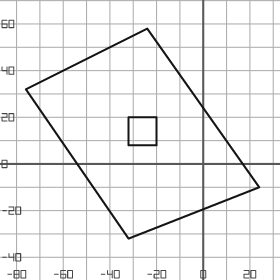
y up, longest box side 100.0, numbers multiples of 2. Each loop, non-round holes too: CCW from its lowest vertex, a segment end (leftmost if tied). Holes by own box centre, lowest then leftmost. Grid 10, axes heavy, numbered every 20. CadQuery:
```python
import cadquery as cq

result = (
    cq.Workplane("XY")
    .moveTo(-32.0, -32.0)
    .lineTo(24.0, -10.0)
    .lineTo(-24.0, 58.0)
    .lineTo(-76.0, 32.0)
    .close()
    .moveTo(-32.0, 8.0)
    .lineTo(-20.0, 8.0)
    .lineTo(-20.0, 20.0)
    .lineTo(-32.0, 20.0)
    .close()
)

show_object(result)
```